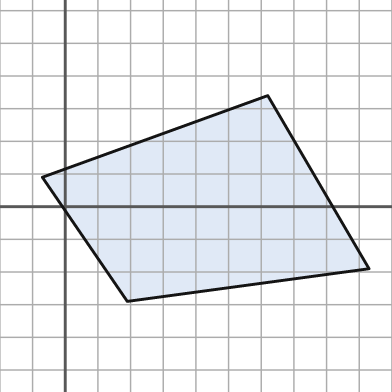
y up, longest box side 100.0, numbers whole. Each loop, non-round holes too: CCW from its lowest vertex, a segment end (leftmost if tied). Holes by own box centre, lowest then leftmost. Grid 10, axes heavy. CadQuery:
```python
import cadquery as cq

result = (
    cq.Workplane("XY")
    .moveTo(19.0, -29.0)
    .lineTo(93.0, -19.0)
    .lineTo(62.0, 34.0)
    .lineTo(-7.0, 9.0)
    .close()
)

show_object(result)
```